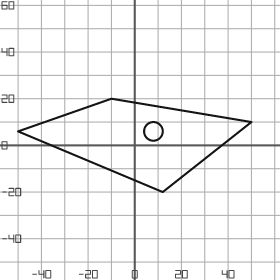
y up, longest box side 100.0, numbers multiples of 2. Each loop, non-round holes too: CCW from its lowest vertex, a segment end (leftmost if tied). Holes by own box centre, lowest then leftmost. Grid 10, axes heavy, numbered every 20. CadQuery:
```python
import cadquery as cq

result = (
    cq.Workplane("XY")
    .moveTo(12.0, -20.0)
    .lineTo(50.0, 10.0)
    .lineTo(-10.0, 20.0)
    .lineTo(-50.0, 6.0)
    .close()
    .moveTo(8.0, 6.0)
    .circle(4.0)
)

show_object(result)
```